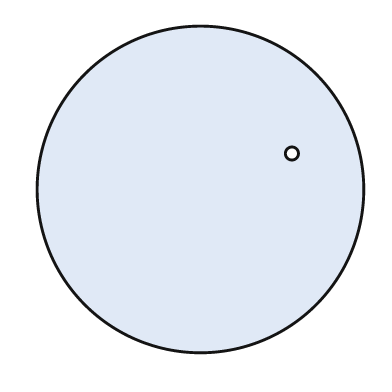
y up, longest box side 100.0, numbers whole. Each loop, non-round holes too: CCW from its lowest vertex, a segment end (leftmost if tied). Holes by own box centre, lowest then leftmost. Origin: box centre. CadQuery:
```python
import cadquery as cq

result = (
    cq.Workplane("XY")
    .moveTo(0.0, 0.0)
    .circle(50.0)
    .moveTo(28.0, 11.0)
    .circle(2.0)
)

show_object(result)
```